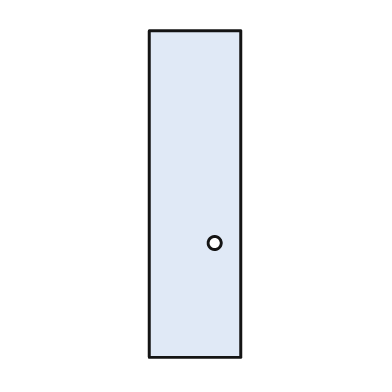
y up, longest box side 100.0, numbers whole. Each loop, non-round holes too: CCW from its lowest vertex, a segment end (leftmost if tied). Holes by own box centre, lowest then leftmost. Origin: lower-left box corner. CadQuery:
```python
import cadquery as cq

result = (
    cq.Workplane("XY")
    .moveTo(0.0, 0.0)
    .lineTo(28.0, 0.0)
    .lineTo(28.0, 100.0)
    .lineTo(0.0, 100.0)
    .close()
    .moveTo(20.0, 35.0)
    .circle(2.0)
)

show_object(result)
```